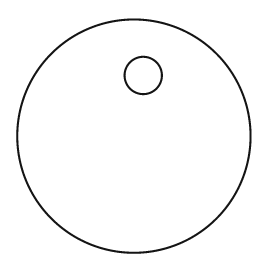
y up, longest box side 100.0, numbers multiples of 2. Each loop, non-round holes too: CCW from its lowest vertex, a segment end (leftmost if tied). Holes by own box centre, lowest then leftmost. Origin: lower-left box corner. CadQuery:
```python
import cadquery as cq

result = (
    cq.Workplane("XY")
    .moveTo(50.0, 50.0)
    .circle(50.0)
    .moveTo(54.0, 76.0)
    .circle(8.0)
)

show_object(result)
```